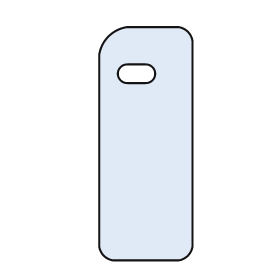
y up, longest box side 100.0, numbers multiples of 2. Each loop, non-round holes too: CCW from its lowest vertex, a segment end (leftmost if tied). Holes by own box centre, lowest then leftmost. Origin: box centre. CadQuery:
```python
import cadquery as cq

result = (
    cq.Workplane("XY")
    .moveTo(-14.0, -50.0)
    .lineTo(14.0, -50.0)
    .threePointArc((18.0, -48.0), (20.0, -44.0))
    .lineTo(20.0, 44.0)
    .threePointArc((18.0, 48.0), (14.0, 50.0))
    .lineTo(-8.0, 50.0)
    .threePointArc((-16.0, 46.0), (-20.0, 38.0))
    .lineTo(-20.0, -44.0)
    .threePointArc((-18.0, -48.0), (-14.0, -50.0))
    .close()
    .moveTo(-8.0, 26.0)
    .lineTo(0.0, 26.0)
    .threePointArc((4.0, 30.0), (0.0, 34.0))
    .lineTo(-8.0, 34.0)
    .threePointArc((-12.0, 30.0), (-8.0, 26.0))
    .close()
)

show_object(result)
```